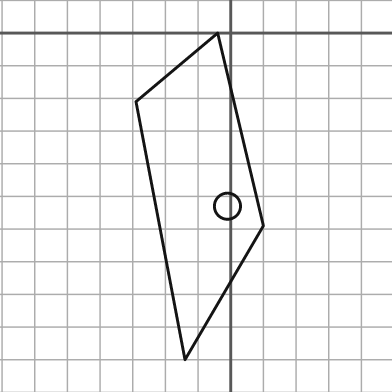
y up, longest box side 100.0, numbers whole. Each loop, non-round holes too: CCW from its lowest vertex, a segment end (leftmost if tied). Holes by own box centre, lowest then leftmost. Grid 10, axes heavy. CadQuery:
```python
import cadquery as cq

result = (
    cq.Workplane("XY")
    .moveTo(-14.0, -100.0)
    .lineTo(10.0, -59.0)
    .lineTo(-4.0, 0.0)
    .lineTo(-29.0, -21.0)
    .close()
    .moveTo(-1.0, -53.0)
    .circle(4.0)
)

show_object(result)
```